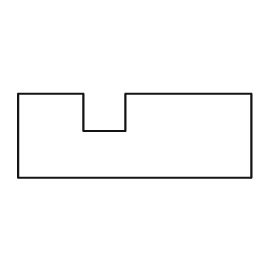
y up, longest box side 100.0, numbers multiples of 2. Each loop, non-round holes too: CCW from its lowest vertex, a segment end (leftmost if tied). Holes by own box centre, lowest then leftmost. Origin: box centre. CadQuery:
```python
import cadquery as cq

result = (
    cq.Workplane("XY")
    .moveTo(-50.0, -18.0)
    .lineTo(50.0, -18.0)
    .lineTo(50.0, 18.0)
    .lineTo(-4.0, 18.0)
    .lineTo(-4.0, 2.0)
    .lineTo(-22.0, 2.0)
    .lineTo(-22.0, 18.0)
    .lineTo(-50.0, 18.0)
    .close()
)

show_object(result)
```